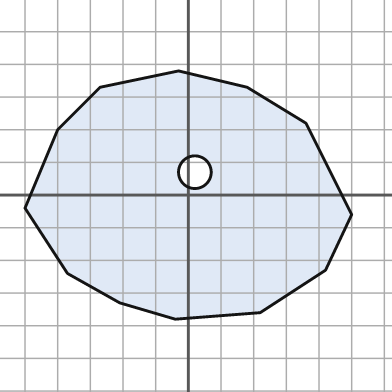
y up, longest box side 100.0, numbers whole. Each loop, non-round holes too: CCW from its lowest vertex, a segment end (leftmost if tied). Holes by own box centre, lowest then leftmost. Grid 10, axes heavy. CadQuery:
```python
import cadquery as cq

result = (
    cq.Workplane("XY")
    .moveTo(-4.0, -38.0)
    .lineTo(22.0, -36.0)
    .lineTo(42.0, -23.0)
    .lineTo(50.0, -6.0)
    .lineTo(36.0, 22.0)
    .lineTo(18.0, 33.0)
    .lineTo(-3.0, 38.0)
    .lineTo(-27.0, 33.0)
    .lineTo(-40.0, 20.0)
    .lineTo(-50.0, -4.0)
    .lineTo(-37.0, -24.0)
    .lineTo(-21.0, -33.0)
    .close()
    .moveTo(2.0, 7.0)
    .circle(5.0)
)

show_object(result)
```